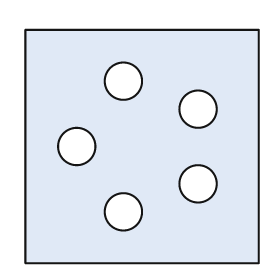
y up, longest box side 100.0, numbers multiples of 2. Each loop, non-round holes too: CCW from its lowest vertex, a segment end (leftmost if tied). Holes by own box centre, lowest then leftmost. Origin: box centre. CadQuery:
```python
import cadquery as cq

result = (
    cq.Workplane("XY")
    .moveTo(-50.0, -50.0)
    .lineTo(50.0, -50.0)
    .lineTo(50.0, 50.0)
    .lineTo(-50.0, 50.0)
    .close()
    .moveTo(-8.0, -28.0)
    .circle(8.0)
    .moveTo(24.0, -16.0)
    .circle(8.0)
    .moveTo(-28.0, 0.0)
    .circle(8.0)
    .moveTo(24.0, 16.0)
    .circle(8.0)
    .moveTo(-8.0, 28.0)
    .circle(8.0)
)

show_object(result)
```